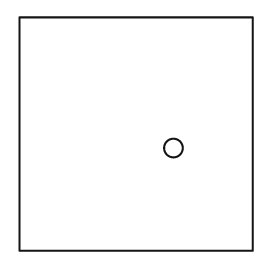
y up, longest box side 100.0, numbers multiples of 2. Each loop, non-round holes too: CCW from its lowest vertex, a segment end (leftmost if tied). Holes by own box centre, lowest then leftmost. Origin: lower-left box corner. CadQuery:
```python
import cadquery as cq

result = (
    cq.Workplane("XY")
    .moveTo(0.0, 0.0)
    .lineTo(100.0, 0.0)
    .lineTo(100.0, 100.0)
    .lineTo(0.0, 100.0)
    .close()
    .moveTo(66.0, 44.0)
    .circle(4.0)
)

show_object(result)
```